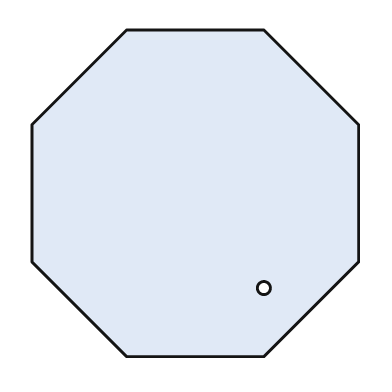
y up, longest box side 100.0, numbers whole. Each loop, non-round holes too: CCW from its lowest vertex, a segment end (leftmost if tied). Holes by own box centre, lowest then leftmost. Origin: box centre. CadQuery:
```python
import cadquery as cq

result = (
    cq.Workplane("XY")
    .moveTo(-21.0, -50.0)
    .lineTo(21.0, -50.0)
    .lineTo(50.0, -21.0)
    .lineTo(50.0, 21.0)
    .lineTo(21.0, 50.0)
    .lineTo(-21.0, 50.0)
    .lineTo(-50.0, 21.0)
    .lineTo(-50.0, -21.0)
    .close()
    .moveTo(21.0, -29.0)
    .circle(2.0)
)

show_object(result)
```